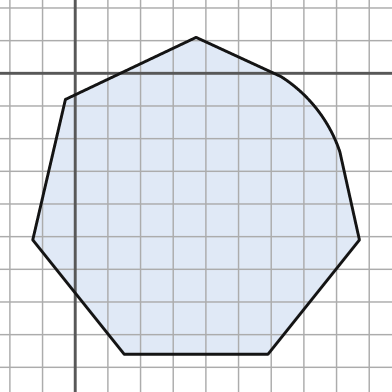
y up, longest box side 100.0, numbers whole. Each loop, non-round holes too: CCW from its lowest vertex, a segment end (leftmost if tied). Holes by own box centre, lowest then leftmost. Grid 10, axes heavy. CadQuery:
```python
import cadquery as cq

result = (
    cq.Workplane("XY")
    .moveTo(15.0, -86.0)
    .lineTo(59.0, -86.0)
    .lineTo(87.0, -51.0)
    .lineTo(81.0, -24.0)
    .threePointArc((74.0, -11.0), (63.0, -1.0))
    .lineTo(37.0, 11.0)
    .lineTo(-3.0, -8.0)
    .lineTo(-13.0, -51.0)
    .close()
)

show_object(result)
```